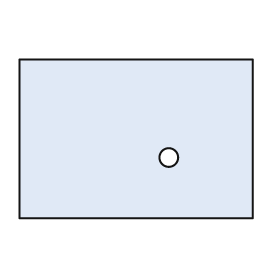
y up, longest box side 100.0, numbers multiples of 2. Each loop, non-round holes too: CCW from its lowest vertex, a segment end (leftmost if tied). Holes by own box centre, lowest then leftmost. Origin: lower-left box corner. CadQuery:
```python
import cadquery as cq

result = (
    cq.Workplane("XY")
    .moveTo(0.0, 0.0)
    .lineTo(100.0, 0.0)
    .lineTo(100.0, 68.0)
    .lineTo(0.0, 68.0)
    .close()
    .moveTo(64.0, 26.0)
    .circle(4.0)
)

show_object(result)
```